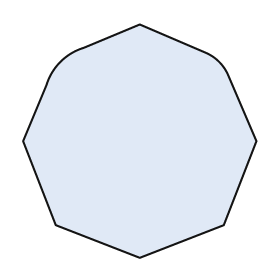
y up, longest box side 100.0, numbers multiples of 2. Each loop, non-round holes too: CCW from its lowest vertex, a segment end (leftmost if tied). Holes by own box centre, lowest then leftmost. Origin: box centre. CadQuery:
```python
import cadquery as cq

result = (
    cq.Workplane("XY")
    .moveTo(0.0, -50.0)
    .lineTo(36.0, -36.0)
    .lineTo(50.0, 0.0)
    .lineTo(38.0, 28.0)
    .threePointArc((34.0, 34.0), (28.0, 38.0))
    .lineTo(0.0, 50.0)
    .lineTo(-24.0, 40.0)
    .threePointArc((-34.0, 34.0), (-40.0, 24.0))
    .lineTo(-50.0, 0.0)
    .lineTo(-36.0, -36.0)
    .close()
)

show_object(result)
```